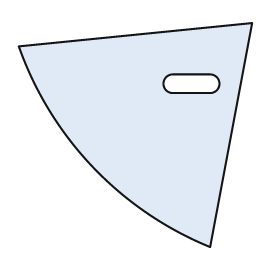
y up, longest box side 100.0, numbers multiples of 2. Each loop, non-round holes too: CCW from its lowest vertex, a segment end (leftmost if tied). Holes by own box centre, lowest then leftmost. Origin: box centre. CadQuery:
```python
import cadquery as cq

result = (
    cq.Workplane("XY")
    .moveTo(32.0, -48.0)
    .lineTo(50.0, 48.0)
    .lineTo(-50.0, 38.0)
    .threePointArc((-18.0, -14.0), (32.0, -48.0))
    .close()
    .moveTo(16.0, 18.0)
    .lineTo(32.0, 18.0)
    .threePointArc((36.0, 22.0), (32.0, 26.0))
    .lineTo(16.0, 26.0)
    .threePointArc((12.0, 22.0), (16.0, 18.0))
    .close()
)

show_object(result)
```